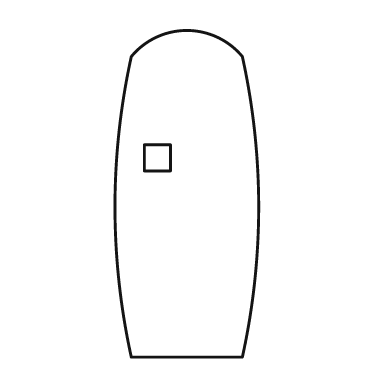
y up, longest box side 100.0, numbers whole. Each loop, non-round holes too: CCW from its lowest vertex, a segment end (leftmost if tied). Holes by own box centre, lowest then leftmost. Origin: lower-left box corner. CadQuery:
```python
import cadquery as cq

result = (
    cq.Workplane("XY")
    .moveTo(5.0, 0.0)
    .lineTo(39.0, 0.0)
    .threePointArc((44.0, 46.0), (39.0, 92.0))
    .threePointArc((22.0, 100.0), (5.0, 92.0))
    .threePointArc((0.0, 46.0), (5.0, 0.0))
    .close()
    .moveTo(9.0, 57.0)
    .lineTo(17.0, 57.0)
    .lineTo(17.0, 65.0)
    .lineTo(9.0, 65.0)
    .close()
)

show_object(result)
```